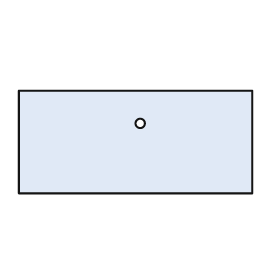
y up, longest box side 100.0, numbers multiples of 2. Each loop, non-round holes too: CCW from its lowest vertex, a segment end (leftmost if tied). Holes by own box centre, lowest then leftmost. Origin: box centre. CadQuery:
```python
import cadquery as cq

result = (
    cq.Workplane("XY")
    .moveTo(-50.0, -22.0)
    .lineTo(50.0, -22.0)
    .lineTo(50.0, 22.0)
    .lineTo(-50.0, 22.0)
    .close()
    .moveTo(2.0, 8.0)
    .circle(2.0)
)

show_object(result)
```